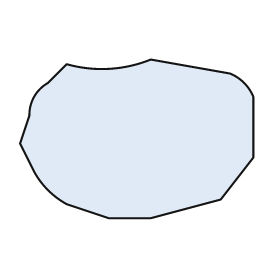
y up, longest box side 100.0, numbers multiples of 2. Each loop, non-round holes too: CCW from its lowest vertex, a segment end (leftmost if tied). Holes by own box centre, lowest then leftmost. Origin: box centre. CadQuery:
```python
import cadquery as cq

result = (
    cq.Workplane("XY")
    .moveTo(-12.0, -34.0)
    .lineTo(6.0, -34.0)
    .lineTo(36.0, -26.0)
    .lineTo(50.0, -8.0)
    .lineTo(50.0, 18.0)
    .threePointArc((46.0, 24.0), (40.0, 28.0))
    .lineTo(6.0, 34.0)
    .threePointArc((-12.0, 30.0), (-30.0, 32.0))
    .lineTo(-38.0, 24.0)
    .threePointArc((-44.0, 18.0), (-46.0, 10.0))
    .lineTo(-50.0, -2.0)
    .lineTo(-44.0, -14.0)
    .threePointArc((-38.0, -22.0), (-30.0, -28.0))
    .close()
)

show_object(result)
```